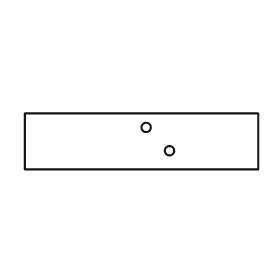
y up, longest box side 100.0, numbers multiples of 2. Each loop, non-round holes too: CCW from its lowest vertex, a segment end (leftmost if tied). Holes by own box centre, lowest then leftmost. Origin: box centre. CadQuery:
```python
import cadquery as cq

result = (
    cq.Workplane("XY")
    .moveTo(-50.0, -12.0)
    .lineTo(50.0, -12.0)
    .lineTo(50.0, 12.0)
    .lineTo(-50.0, 12.0)
    .close()
    .moveTo(12.0, -4.0)
    .circle(2.0)
    .moveTo(2.0, 6.0)
    .circle(2.0)
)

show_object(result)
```